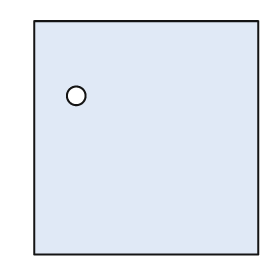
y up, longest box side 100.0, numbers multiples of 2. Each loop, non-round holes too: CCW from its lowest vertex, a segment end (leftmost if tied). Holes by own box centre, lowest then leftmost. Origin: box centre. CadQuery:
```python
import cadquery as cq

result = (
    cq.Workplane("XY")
    .moveTo(-48.0, -50.0)
    .lineTo(48.0, -50.0)
    .lineTo(48.0, 50.0)
    .lineTo(-48.0, 50.0)
    .close()
    .moveTo(-30.0, 18.0)
    .circle(4.0)
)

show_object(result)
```